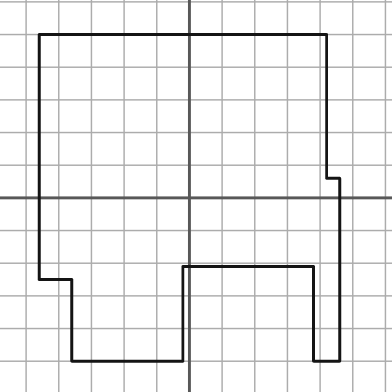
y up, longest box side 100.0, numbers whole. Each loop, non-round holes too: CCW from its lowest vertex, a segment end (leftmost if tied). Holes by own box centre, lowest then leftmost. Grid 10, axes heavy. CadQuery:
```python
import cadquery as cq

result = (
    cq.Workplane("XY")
    .moveTo(-36.0, -50.0)
    .lineTo(-2.0, -50.0)
    .lineTo(-2.0, -21.0)
    .lineTo(38.0, -21.0)
    .lineTo(38.0, -50.0)
    .lineTo(46.0, -50.0)
    .lineTo(46.0, 6.0)
    .lineTo(42.0, 6.0)
    .lineTo(42.0, 50.0)
    .lineTo(-46.0, 50.0)
    .lineTo(-46.0, -25.0)
    .lineTo(-36.0, -25.0)
    .close()
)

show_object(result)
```